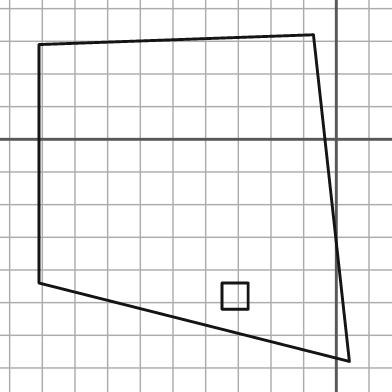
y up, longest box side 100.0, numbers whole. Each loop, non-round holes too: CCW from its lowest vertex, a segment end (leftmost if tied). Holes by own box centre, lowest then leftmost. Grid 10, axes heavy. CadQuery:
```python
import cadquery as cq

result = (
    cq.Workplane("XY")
    .moveTo(4.0, -68.0)
    .lineTo(-7.0, 32.0)
    .lineTo(-91.0, 29.0)
    .lineTo(-91.0, -44.0)
    .close()
    .moveTo(-35.0, -52.0)
    .lineTo(-27.0, -52.0)
    .lineTo(-27.0, -44.0)
    .lineTo(-35.0, -44.0)
    .close()
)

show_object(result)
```